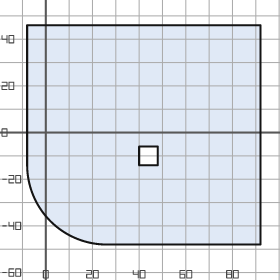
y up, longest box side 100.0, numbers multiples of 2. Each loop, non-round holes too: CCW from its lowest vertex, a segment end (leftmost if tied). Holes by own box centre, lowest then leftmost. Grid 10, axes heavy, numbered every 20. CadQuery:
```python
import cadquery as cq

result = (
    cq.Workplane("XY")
    .moveTo(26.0, -48.0)
    .lineTo(92.0, -48.0)
    .lineTo(92.0, 46.0)
    .lineTo(-8.0, 46.0)
    .lineTo(-8.0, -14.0)
    .threePointArc((2.0, -38.0), (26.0, -48.0))
    .close()
    .moveTo(40.0, -14.0)
    .lineTo(48.0, -14.0)
    .lineTo(48.0, -6.0)
    .lineTo(40.0, -6.0)
    .close()
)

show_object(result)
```